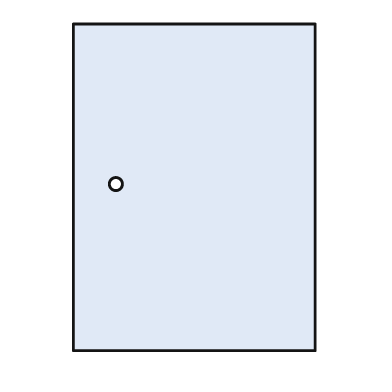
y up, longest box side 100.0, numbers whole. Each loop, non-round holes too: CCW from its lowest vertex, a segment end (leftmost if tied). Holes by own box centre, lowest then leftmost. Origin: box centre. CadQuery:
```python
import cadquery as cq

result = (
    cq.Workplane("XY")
    .moveTo(-37.0, -50.0)
    .lineTo(37.0, -50.0)
    .lineTo(37.0, 50.0)
    .lineTo(-37.0, 50.0)
    .close()
    .moveTo(-24.0, 1.0)
    .circle(2.0)
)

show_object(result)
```